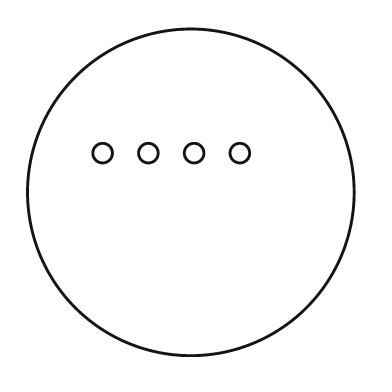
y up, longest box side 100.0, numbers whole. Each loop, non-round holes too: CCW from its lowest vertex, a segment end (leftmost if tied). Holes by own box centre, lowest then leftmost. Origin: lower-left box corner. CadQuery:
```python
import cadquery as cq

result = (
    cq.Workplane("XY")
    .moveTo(50.0, 50.0)
    .circle(50.0)
    .moveTo(23.0, 62.0)
    .circle(3.0)
    .moveTo(37.0, 62.0)
    .circle(3.0)
    .moveTo(51.0, 62.0)
    .circle(3.0)
    .moveTo(65.0, 62.0)
    .circle(3.0)
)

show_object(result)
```